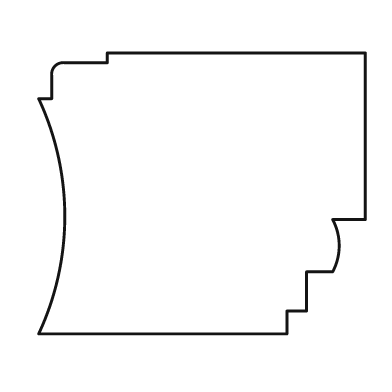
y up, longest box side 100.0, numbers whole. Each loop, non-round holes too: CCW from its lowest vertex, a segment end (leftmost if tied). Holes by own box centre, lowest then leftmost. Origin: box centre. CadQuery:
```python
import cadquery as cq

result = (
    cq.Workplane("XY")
    .moveTo(-50.0, -43.0)
    .lineTo(26.0, -43.0)
    .lineTo(26.0, -36.0)
    .lineTo(32.0, -36.0)
    .lineTo(32.0, -24.0)
    .lineTo(40.0, -24.0)
    .threePointArc((42.0, -16.0), (40.0, -8.0))
    .lineTo(50.0, -8.0)
    .lineTo(50.0, 43.0)
    .lineTo(-29.0, 43.0)
    .lineTo(-29.0, 40.0)
    .lineTo(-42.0, 40.0)
    .threePointArc((-45.0, 39.0), (-46.0, 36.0))
    .lineTo(-46.0, 29.0)
    .lineTo(-50.0, 29.0)
    .threePointArc((-42.0, -7.0), (-50.0, -43.0))
    .close()
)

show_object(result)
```